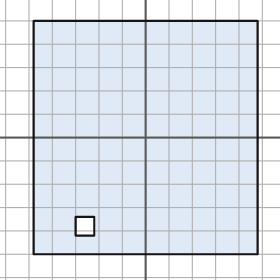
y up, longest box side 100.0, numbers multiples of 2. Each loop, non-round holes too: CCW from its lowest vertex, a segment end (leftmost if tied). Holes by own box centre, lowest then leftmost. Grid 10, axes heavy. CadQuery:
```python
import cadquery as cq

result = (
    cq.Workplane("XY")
    .moveTo(-48.0, -50.0)
    .lineTo(48.0, -50.0)
    .lineTo(48.0, 50.0)
    .lineTo(-48.0, 50.0)
    .close()
    .moveTo(-30.0, -42.0)
    .lineTo(-22.0, -42.0)
    .lineTo(-22.0, -34.0)
    .lineTo(-30.0, -34.0)
    .close()
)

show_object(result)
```